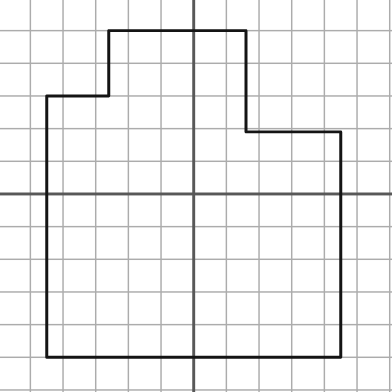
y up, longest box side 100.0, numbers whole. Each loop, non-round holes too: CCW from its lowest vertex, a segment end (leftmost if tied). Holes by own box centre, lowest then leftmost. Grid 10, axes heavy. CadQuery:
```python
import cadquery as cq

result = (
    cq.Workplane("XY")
    .moveTo(-45.0, -50.0)
    .lineTo(45.0, -50.0)
    .lineTo(45.0, 19.0)
    .lineTo(16.0, 19.0)
    .lineTo(16.0, 50.0)
    .lineTo(-26.0, 50.0)
    .lineTo(-26.0, 30.0)
    .lineTo(-45.0, 30.0)
    .close()
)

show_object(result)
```